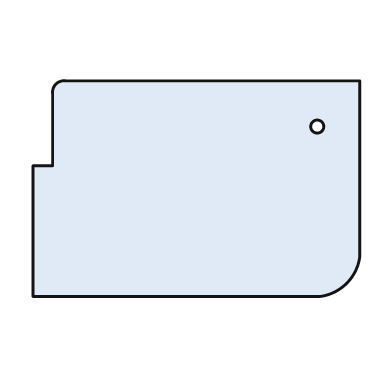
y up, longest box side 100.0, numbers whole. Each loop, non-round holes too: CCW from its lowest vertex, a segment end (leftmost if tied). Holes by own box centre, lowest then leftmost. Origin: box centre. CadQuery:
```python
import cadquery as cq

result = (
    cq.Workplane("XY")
    .moveTo(-50.0, -33.0)
    .lineTo(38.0, -33.0)
    .threePointArc((46.0, -29.0), (50.0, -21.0))
    .lineTo(50.0, 33.0)
    .lineTo(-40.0, 33.0)
    .threePointArc((-43.0, 32.0), (-44.0, 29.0))
    .lineTo(-44.0, 7.0)
    .lineTo(-50.0, 7.0)
    .close()
    .moveTo(37.0, 19.0)
    .circle(2.0)
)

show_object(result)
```